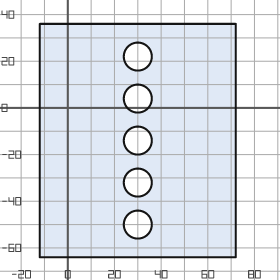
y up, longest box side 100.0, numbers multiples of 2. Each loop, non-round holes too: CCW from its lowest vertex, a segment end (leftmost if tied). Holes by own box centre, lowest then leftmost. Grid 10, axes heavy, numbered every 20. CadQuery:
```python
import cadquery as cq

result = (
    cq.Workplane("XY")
    .moveTo(-12.0, -64.0)
    .lineTo(72.0, -64.0)
    .lineTo(72.0, 36.0)
    .lineTo(-12.0, 36.0)
    .close()
    .moveTo(30.0, -50.0)
    .circle(6.0)
    .moveTo(30.0, -32.0)
    .circle(6.0)
    .moveTo(30.0, -14.0)
    .circle(6.0)
    .moveTo(30.0, 4.0)
    .circle(6.0)
    .moveTo(30.0, 22.0)
    .circle(6.0)
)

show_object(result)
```